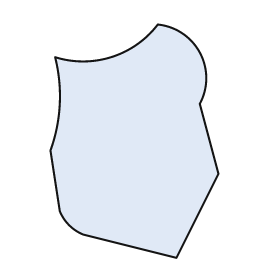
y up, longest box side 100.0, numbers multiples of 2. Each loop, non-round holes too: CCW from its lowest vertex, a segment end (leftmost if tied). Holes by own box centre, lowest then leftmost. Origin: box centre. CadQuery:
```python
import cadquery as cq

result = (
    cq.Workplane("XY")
    .moveTo(18.0, -50.0)
    .lineTo(36.0, -14.0)
    .lineTo(28.0, 16.0)
    .threePointArc((28.0, 38.0), (10.0, 50.0))
    .threePointArc((-10.0, 36.0), (-34.0, 36.0))
    .threePointArc((-32.0, 16.0), (-36.0, -4.0))
    .lineTo(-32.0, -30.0)
    .threePointArc((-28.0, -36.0), (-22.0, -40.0))
    .close()
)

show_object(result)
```